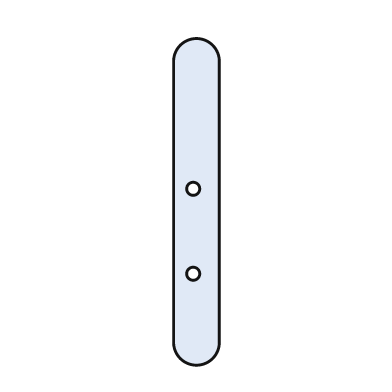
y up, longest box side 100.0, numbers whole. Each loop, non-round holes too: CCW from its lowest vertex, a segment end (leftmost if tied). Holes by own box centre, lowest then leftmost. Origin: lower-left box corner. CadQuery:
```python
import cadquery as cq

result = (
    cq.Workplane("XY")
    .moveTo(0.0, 7.0)
    .threePointArc((7.0, 0.0), (14.0, 7.0))
    .lineTo(14.0, 93.0)
    .threePointArc((7.0, 100.0), (0.0, 93.0))
    .close()
    .moveTo(6.0, 28.0)
    .circle(2.0)
    .moveTo(6.0, 54.0)
    .circle(2.0)
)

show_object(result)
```